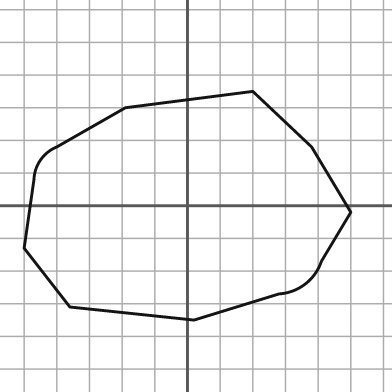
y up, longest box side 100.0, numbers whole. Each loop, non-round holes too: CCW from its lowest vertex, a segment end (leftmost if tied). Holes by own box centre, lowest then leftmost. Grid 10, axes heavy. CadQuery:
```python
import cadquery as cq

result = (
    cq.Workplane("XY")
    .moveTo(2.0, -35.0)
    .lineTo(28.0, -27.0)
    .threePointArc((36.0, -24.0), (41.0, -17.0))
    .lineTo(50.0, -2.0)
    .lineTo(38.0, 18.0)
    .lineTo(20.0, 35.0)
    .lineTo(-19.0, 30.0)
    .lineTo(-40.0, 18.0)
    .threePointArc((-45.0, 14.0), (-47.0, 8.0))
    .lineTo(-50.0, -13.0)
    .lineTo(-36.0, -31.0)
    .close()
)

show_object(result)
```